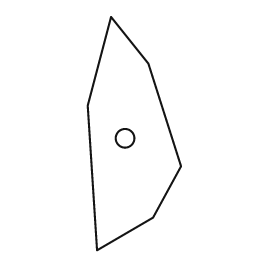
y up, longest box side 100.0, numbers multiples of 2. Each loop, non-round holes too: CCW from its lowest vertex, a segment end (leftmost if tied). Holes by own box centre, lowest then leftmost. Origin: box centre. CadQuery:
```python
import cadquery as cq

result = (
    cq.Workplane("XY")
    .moveTo(-16.0, -50.0)
    .lineTo(8.0, -36.0)
    .lineTo(20.0, -14.0)
    .lineTo(6.0, 30.0)
    .lineTo(-10.0, 50.0)
    .lineTo(-20.0, 12.0)
    .close()
    .moveTo(-4.0, -2.0)
    .circle(4.0)
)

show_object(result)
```